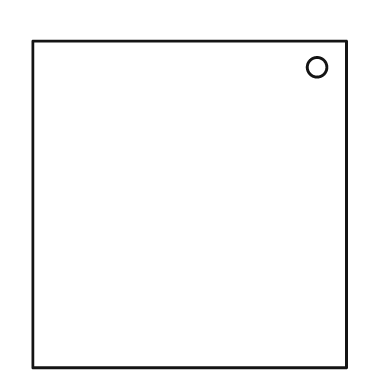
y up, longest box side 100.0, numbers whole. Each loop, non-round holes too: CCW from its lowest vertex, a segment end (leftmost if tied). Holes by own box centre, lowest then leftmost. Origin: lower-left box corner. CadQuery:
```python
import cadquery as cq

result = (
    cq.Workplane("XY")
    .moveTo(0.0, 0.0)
    .lineTo(96.0, 0.0)
    .lineTo(96.0, 100.0)
    .lineTo(0.0, 100.0)
    .close()
    .moveTo(87.0, 92.0)
    .circle(3.0)
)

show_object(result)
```